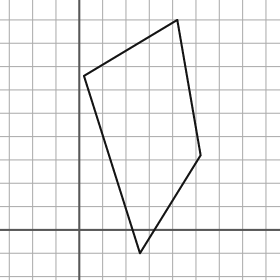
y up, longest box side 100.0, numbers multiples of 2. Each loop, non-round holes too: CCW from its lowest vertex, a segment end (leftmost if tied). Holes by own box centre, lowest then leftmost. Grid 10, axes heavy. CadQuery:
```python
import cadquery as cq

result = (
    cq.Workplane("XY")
    .moveTo(26.0, -10.0)
    .lineTo(52.0, 32.0)
    .lineTo(42.0, 90.0)
    .lineTo(2.0, 66.0)
    .close()
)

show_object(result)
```